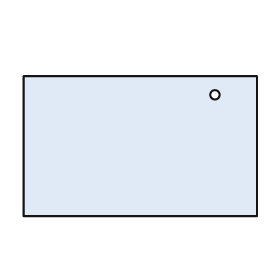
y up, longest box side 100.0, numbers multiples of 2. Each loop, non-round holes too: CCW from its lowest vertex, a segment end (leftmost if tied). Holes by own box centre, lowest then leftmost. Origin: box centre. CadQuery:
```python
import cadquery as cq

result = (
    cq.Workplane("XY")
    .moveTo(-50.0, -30.0)
    .lineTo(50.0, -30.0)
    .lineTo(50.0, 30.0)
    .lineTo(-50.0, 30.0)
    .close()
    .moveTo(32.0, 22.0)
    .circle(2.0)
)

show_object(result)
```